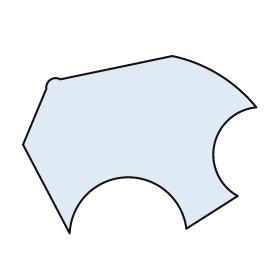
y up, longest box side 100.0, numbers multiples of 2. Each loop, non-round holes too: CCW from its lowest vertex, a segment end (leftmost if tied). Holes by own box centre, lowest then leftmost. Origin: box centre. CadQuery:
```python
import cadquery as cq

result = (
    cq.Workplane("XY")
    .moveTo(-30.0, -38.0)
    .threePointArc((-6.0, -14.0), (20.0, -36.0))
    .lineTo(42.0, -22.0)
    .threePointArc((32.0, 0.0), (50.0, 16.0))
    .threePointArc((34.0, 30.0), (14.0, 38.0))
    .lineTo(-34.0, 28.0)
    .threePointArc((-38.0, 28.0), (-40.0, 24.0))
    .lineTo(-50.0, 0.0)
    .close()
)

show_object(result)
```